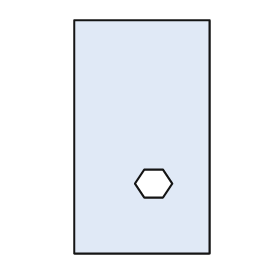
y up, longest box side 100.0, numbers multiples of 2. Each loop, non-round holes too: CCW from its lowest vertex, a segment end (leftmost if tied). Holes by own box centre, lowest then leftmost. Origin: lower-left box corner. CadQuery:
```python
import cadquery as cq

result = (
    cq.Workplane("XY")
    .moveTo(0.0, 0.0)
    .lineTo(58.0, 0.0)
    .lineTo(58.0, 100.0)
    .lineTo(0.0, 100.0)
    .close()
    .moveTo(30.0, 24.0)
    .lineTo(38.0, 24.0)
    .lineTo(42.0, 30.0)
    .lineTo(38.0, 36.0)
    .lineTo(30.0, 36.0)
    .lineTo(26.0, 30.0)
    .close()
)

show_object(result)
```